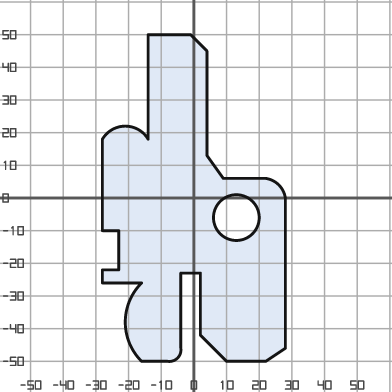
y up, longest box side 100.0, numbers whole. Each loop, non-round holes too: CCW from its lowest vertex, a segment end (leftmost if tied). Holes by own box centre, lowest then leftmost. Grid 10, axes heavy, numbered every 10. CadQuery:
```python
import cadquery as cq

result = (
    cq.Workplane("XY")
    .moveTo(-16.0, -50.0)
    .lineTo(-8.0, -50.0)
    .threePointArc((-5.0, -49.0), (-4.0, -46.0))
    .lineTo(-4.0, -23.0)
    .lineTo(2.0, -23.0)
    .lineTo(2.0, -42.0)
    .lineTo(10.0, -50.0)
    .lineTo(22.0, -50.0)
    .lineTo(28.0, -46.0)
    .lineTo(28.0, 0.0)
    .threePointArc((26.0, 4.0), (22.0, 6.0))
    .lineTo(9.0, 6.0)
    .lineTo(4.0, 13.0)
    .lineTo(4.0, 45.0)
    .lineTo(-1.0, 50.0)
    .lineTo(-14.0, 50.0)
    .lineTo(-14.0, 18.0)
    .threePointArc((-21.0, 22.0), (-28.0, 18.0))
    .lineTo(-28.0, -10.0)
    .lineTo(-23.0, -10.0)
    .lineTo(-23.0, -22.0)
    .lineTo(-28.0, -22.0)
    .lineTo(-28.0, -26.0)
    .lineTo(-16.0, -26.0)
    .threePointArc((-21.0, -38.0), (-16.0, -50.0))
    .close()
    .moveTo(13.0, -6.0)
    .circle(7.0)
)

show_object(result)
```